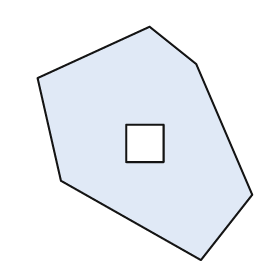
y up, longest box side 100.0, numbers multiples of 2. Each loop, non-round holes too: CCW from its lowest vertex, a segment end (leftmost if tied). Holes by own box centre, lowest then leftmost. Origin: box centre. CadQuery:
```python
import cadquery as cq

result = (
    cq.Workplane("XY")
    .moveTo(24.0, -50.0)
    .lineTo(46.0, -22.0)
    .lineTo(22.0, 34.0)
    .lineTo(2.0, 50.0)
    .lineTo(-46.0, 28.0)
    .lineTo(-36.0, -16.0)
    .close()
    .moveTo(-8.0, -8.0)
    .lineTo(8.0, -8.0)
    .lineTo(8.0, 8.0)
    .lineTo(-8.0, 8.0)
    .close()
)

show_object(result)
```